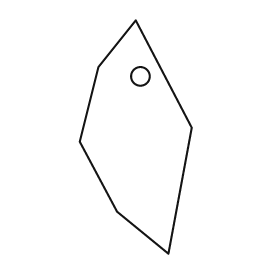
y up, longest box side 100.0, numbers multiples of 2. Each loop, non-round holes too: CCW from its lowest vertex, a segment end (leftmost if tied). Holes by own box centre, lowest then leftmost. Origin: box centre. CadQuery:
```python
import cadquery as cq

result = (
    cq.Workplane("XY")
    .moveTo(14.0, -50.0)
    .lineTo(24.0, 4.0)
    .lineTo(0.0, 50.0)
    .lineTo(-16.0, 30.0)
    .lineTo(-24.0, -2.0)
    .lineTo(-8.0, -32.0)
    .close()
    .moveTo(2.0, 26.0)
    .circle(4.0)
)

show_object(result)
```